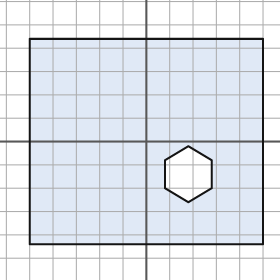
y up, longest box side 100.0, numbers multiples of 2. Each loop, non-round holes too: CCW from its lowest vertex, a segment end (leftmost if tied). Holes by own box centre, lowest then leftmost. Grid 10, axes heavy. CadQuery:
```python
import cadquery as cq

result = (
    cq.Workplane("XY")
    .moveTo(-50.0, -44.0)
    .lineTo(50.0, -44.0)
    .lineTo(50.0, 44.0)
    .lineTo(-50.0, 44.0)
    .close()
    .moveTo(18.0, -26.0)
    .lineTo(28.0, -20.0)
    .lineTo(28.0, -8.0)
    .lineTo(18.0, -2.0)
    .lineTo(8.0, -8.0)
    .lineTo(8.0, -20.0)
    .close()
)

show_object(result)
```